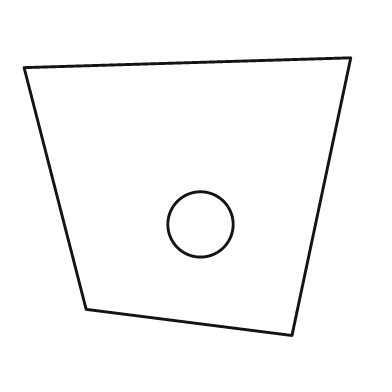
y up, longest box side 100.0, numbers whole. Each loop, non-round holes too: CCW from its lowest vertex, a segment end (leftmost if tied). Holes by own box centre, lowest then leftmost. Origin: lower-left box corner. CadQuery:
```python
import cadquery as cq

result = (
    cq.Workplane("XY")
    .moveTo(82.0, 0.0)
    .lineTo(100.0, 85.0)
    .lineTo(0.0, 82.0)
    .lineTo(19.0, 8.0)
    .close()
    .moveTo(54.0, 34.0)
    .circle(10.0)
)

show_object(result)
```